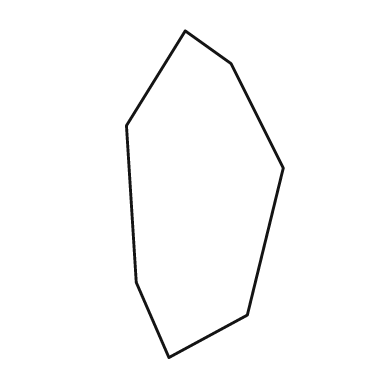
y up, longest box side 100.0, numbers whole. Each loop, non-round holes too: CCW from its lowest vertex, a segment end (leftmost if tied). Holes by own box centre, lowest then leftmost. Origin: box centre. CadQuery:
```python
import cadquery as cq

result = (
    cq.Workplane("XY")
    .moveTo(-11.0, -50.0)
    .lineTo(13.0, -37.0)
    .lineTo(24.0, 8.0)
    .lineTo(8.0, 40.0)
    .lineTo(-6.0, 50.0)
    .lineTo(-24.0, 21.0)
    .lineTo(-21.0, -27.0)
    .close()
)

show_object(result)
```